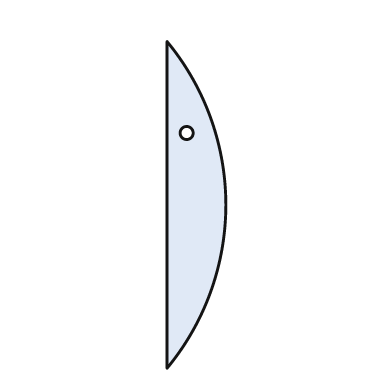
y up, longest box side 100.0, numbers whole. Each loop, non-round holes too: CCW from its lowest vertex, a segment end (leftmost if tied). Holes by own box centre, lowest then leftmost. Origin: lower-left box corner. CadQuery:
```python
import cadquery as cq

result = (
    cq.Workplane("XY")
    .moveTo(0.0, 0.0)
    .threePointArc((18.0, 50.0), (0.0, 100.0))
    .close()
    .moveTo(6.0, 72.0)
    .circle(2.0)
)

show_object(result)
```